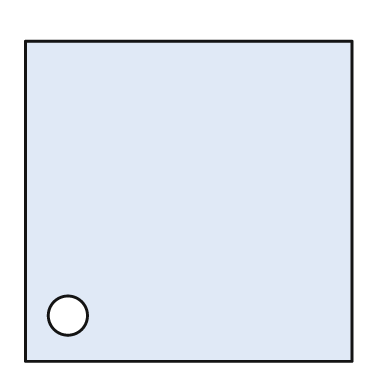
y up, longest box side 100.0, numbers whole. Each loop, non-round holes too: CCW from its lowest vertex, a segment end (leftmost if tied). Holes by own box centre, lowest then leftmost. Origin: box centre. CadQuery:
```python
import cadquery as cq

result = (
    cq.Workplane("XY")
    .moveTo(-50.0, -49.0)
    .lineTo(50.0, -49.0)
    .lineTo(50.0, 49.0)
    .lineTo(-50.0, 49.0)
    .close()
    .moveTo(-37.0, -35.0)
    .circle(6.0)
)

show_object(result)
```